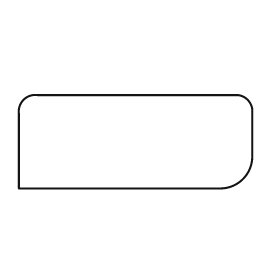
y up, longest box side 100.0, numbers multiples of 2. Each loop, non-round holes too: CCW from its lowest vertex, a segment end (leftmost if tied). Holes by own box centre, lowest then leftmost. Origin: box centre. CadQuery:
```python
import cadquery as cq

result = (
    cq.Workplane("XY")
    .moveTo(-50.0, -20.0)
    .lineTo(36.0, -20.0)
    .threePointArc((46.0, -16.0), (50.0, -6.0))
    .lineTo(50.0, 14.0)
    .threePointArc((48.0, 18.0), (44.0, 20.0))
    .lineTo(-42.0, 20.0)
    .threePointArc((-48.0, 18.0), (-50.0, 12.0))
    .close()
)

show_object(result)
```